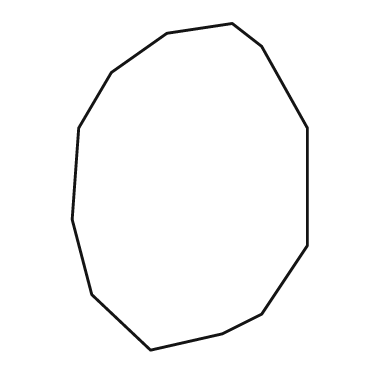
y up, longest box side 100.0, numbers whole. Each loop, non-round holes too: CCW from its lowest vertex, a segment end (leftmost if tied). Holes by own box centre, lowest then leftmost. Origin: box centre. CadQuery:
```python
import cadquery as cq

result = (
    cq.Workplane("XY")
    .moveTo(-12.0, -50.0)
    .lineTo(10.0, -45.0)
    .lineTo(22.0, -39.0)
    .lineTo(36.0, -18.0)
    .lineTo(36.0, 18.0)
    .lineTo(22.0, 43.0)
    .lineTo(13.0, 50.0)
    .lineTo(-7.0, 47.0)
    .lineTo(-24.0, 35.0)
    .lineTo(-34.0, 18.0)
    .lineTo(-36.0, -10.0)
    .lineTo(-30.0, -33.0)
    .close()
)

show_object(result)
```